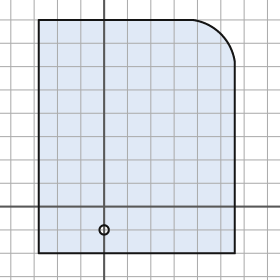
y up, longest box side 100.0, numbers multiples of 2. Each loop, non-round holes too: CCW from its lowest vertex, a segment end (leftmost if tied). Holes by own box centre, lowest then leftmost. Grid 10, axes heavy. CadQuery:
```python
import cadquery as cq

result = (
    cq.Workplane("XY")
    .moveTo(-28.0, -20.0)
    .lineTo(56.0, -20.0)
    .lineTo(56.0, 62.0)
    .threePointArc((50.0, 74.0), (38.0, 80.0))
    .lineTo(-28.0, 80.0)
    .close()
    .moveTo(0.0, -10.0)
    .circle(2.0)
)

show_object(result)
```